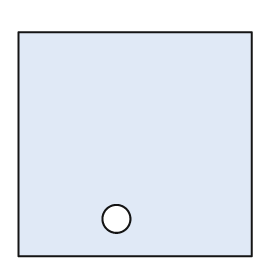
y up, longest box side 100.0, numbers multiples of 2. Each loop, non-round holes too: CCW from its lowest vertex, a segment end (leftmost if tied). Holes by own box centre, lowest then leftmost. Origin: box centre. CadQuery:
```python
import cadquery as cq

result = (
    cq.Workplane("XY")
    .moveTo(-50.0, -48.0)
    .lineTo(50.0, -48.0)
    .lineTo(50.0, 48.0)
    .lineTo(-50.0, 48.0)
    .close()
    .moveTo(-8.0, -32.0)
    .circle(6.0)
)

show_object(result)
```